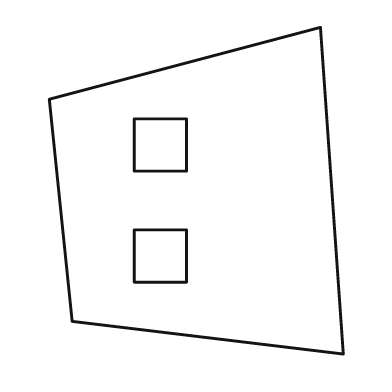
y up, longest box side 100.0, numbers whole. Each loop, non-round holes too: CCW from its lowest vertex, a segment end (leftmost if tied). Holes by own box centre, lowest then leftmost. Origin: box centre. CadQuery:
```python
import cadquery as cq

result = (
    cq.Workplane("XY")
    .moveTo(45.0, -50.0)
    .lineTo(38.0, 50.0)
    .lineTo(-45.0, 28.0)
    .lineTo(-38.0, -40.0)
    .close()
    .moveTo(-19.0, -28.0)
    .lineTo(-3.0, -28.0)
    .lineTo(-3.0, -12.0)
    .lineTo(-19.0, -12.0)
    .close()
    .moveTo(-19.0, 6.0)
    .lineTo(-3.0, 6.0)
    .lineTo(-3.0, 22.0)
    .lineTo(-19.0, 22.0)
    .close()
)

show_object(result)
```